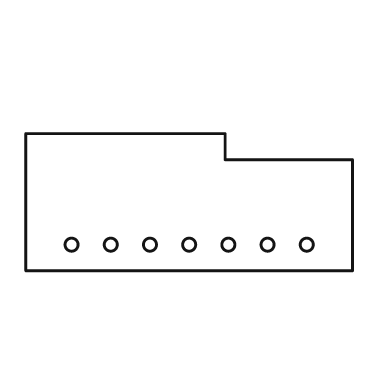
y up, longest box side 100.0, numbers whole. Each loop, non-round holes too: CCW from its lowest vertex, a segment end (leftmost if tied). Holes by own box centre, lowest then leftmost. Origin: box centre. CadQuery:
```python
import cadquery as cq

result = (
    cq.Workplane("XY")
    .moveTo(-50.0, -21.0)
    .lineTo(50.0, -21.0)
    .lineTo(50.0, 13.0)
    .lineTo(11.0, 13.0)
    .lineTo(11.0, 21.0)
    .lineTo(-50.0, 21.0)
    .close()
    .moveTo(-36.0, -13.0)
    .circle(2.0)
    .moveTo(-24.0, -13.0)
    .circle(2.0)
    .moveTo(-12.0, -13.0)
    .circle(2.0)
    .moveTo(0.0, -13.0)
    .circle(2.0)
    .moveTo(12.0, -13.0)
    .circle(2.0)
    .moveTo(24.0, -13.0)
    .circle(2.0)
    .moveTo(36.0, -13.0)
    .circle(2.0)
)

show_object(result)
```